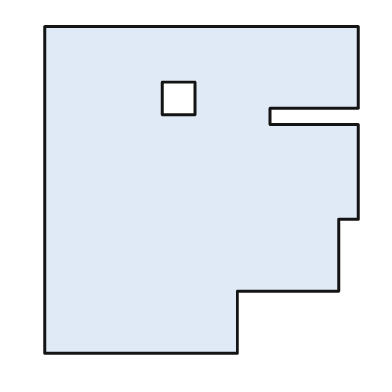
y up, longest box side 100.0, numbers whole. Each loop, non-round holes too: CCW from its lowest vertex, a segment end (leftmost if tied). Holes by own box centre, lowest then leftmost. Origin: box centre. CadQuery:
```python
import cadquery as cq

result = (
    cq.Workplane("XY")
    .moveTo(-48.0, -50.0)
    .lineTo(11.0, -50.0)
    .lineTo(11.0, -31.0)
    .lineTo(42.0, -31.0)
    .lineTo(42.0, -9.0)
    .lineTo(48.0, -9.0)
    .lineTo(48.0, 20.0)
    .lineTo(21.0, 20.0)
    .lineTo(21.0, 25.0)
    .lineTo(48.0, 25.0)
    .lineTo(48.0, 50.0)
    .lineTo(-48.0, 50.0)
    .close()
    .moveTo(-12.0, 23.0)
    .lineTo(-2.0, 23.0)
    .lineTo(-2.0, 33.0)
    .lineTo(-12.0, 33.0)
    .close()
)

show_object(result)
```